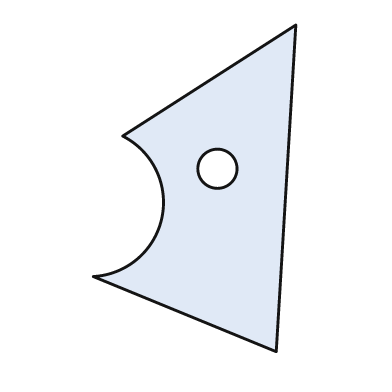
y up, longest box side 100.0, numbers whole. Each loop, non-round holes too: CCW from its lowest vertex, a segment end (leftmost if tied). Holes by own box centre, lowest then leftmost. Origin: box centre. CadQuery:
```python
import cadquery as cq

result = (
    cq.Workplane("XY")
    .moveTo(25.0, -50.0)
    .lineTo(31.0, 50.0)
    .lineTo(-22.0, 16.0)
    .threePointArc((-10.0, -9.0), (-31.0, -27.0))
    .close()
    .moveTo(7.0, 6.0)
    .circle(6.0)
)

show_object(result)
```